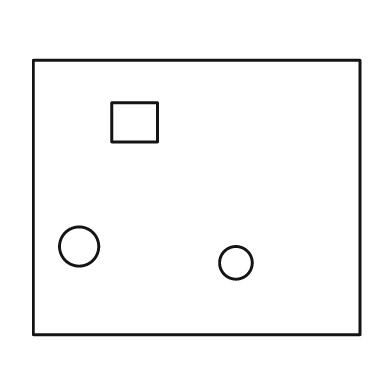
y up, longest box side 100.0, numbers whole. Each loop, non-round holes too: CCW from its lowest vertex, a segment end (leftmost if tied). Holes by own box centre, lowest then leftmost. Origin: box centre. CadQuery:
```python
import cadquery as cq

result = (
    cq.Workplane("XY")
    .moveTo(-50.0, -42.0)
    .lineTo(50.0, -42.0)
    .lineTo(50.0, 42.0)
    .lineTo(-50.0, 42.0)
    .close()
    .moveTo(12.0, -20.0)
    .circle(5.0)
    .moveTo(-36.0, -15.0)
    .circle(6.0)
    .moveTo(-26.0, 17.0)
    .lineTo(-12.0, 17.0)
    .lineTo(-12.0, 29.0)
    .lineTo(-26.0, 29.0)
    .close()
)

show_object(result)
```